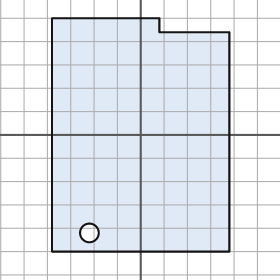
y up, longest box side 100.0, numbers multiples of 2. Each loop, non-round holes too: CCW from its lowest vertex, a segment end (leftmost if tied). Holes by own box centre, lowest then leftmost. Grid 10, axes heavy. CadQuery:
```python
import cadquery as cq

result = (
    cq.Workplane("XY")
    .moveTo(-38.0, -50.0)
    .lineTo(38.0, -50.0)
    .lineTo(38.0, 44.0)
    .lineTo(8.0, 44.0)
    .lineTo(8.0, 50.0)
    .lineTo(-38.0, 50.0)
    .close()
    .moveTo(-22.0, -42.0)
    .circle(4.0)
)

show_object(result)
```